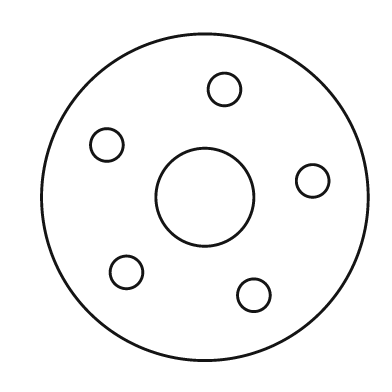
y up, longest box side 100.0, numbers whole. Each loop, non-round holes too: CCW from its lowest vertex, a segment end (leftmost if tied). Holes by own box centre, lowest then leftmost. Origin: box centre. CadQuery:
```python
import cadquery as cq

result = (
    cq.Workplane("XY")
    .moveTo(0.0, 0.0)
    .circle(50.0)
    .moveTo(15.0, -30.0)
    .circle(5.0)
    .moveTo(-24.0, -23.0)
    .circle(5.0)
    .moveTo(0.0, 0.0)
    .circle(15.0)
    .moveTo(33.0, 5.0)
    .circle(5.0)
    .moveTo(-30.0, 16.0)
    .circle(5.0)
    .moveTo(6.0, 33.0)
    .circle(5.0)
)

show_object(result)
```